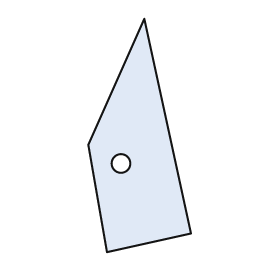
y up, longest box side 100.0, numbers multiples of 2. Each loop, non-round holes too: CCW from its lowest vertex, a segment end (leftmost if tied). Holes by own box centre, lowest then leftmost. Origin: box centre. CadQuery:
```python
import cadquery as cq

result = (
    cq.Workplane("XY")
    .moveTo(-14.0, -50.0)
    .lineTo(22.0, -42.0)
    .lineTo(2.0, 50.0)
    .lineTo(-22.0, -4.0)
    .close()
    .moveTo(-8.0, -12.0)
    .circle(4.0)
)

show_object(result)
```